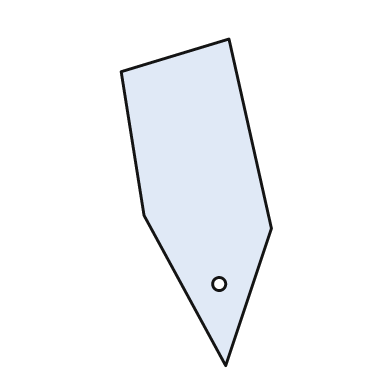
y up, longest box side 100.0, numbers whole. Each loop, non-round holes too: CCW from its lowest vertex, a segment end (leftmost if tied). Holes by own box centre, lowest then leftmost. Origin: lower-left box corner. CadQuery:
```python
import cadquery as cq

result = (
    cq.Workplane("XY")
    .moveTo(32.0, 0.0)
    .lineTo(46.0, 42.0)
    .lineTo(33.0, 100.0)
    .lineTo(0.0, 90.0)
    .lineTo(7.0, 46.0)
    .close()
    .moveTo(30.0, 25.0)
    .circle(2.0)
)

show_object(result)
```